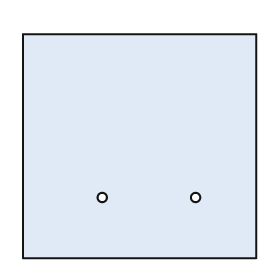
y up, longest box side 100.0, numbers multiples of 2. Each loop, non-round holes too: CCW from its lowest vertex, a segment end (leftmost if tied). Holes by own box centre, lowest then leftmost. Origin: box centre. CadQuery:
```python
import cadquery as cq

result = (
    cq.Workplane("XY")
    .moveTo(-50.0, -48.0)
    .lineTo(50.0, -48.0)
    .lineTo(50.0, 48.0)
    .lineTo(-50.0, 48.0)
    .close()
    .moveTo(-16.0, -22.0)
    .circle(2.0)
    .moveTo(24.0, -22.0)
    .circle(2.0)
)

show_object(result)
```